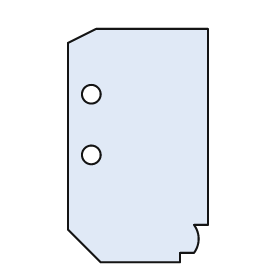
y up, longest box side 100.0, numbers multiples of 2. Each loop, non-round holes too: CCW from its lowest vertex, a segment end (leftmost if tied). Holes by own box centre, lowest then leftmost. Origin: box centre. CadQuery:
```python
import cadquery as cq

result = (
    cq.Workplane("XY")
    .moveTo(-16.0, -50.0)
    .lineTo(18.0, -50.0)
    .lineTo(18.0, -46.0)
    .lineTo(24.0, -46.0)
    .threePointArc((26.0, -40.0), (24.0, -34.0))
    .lineTo(30.0, -34.0)
    .lineTo(30.0, 50.0)
    .lineTo(-18.0, 50.0)
    .lineTo(-30.0, 44.0)
    .lineTo(-30.0, -36.0)
    .close()
    .moveTo(-20.0, -4.0)
    .circle(4.0)
    .moveTo(-20.0, 22.0)
    .circle(4.0)
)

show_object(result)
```